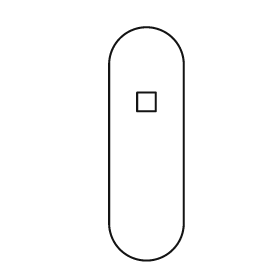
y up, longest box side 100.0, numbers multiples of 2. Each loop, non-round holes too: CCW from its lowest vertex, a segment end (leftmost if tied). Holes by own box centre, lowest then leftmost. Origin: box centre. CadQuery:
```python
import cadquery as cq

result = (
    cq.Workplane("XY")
    .moveTo(-16.0, -34.0)
    .threePointArc((0.0, -50.0), (16.0, -34.0))
    .lineTo(16.0, 34.0)
    .threePointArc((0.0, 50.0), (-16.0, 34.0))
    .close()
    .moveTo(-4.0, 14.0)
    .lineTo(4.0, 14.0)
    .lineTo(4.0, 22.0)
    .lineTo(-4.0, 22.0)
    .close()
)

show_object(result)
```